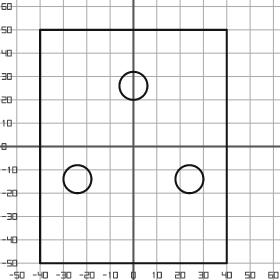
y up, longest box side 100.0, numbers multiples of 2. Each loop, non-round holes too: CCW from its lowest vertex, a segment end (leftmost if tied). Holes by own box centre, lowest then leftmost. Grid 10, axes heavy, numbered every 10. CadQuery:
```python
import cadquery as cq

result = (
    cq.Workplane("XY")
    .moveTo(-40.0, -50.0)
    .lineTo(40.0, -50.0)
    .lineTo(40.0, 50.0)
    .lineTo(-40.0, 50.0)
    .close()
    .moveTo(-24.0, -14.0)
    .circle(6.0)
    .moveTo(24.0, -14.0)
    .circle(6.0)
    .moveTo(0.0, 26.0)
    .circle(6.0)
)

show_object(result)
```